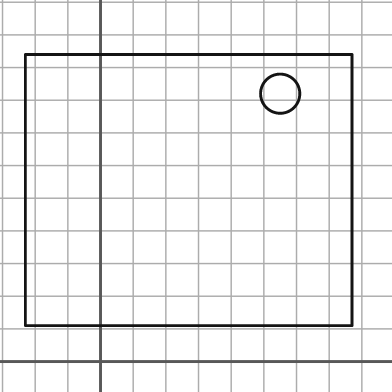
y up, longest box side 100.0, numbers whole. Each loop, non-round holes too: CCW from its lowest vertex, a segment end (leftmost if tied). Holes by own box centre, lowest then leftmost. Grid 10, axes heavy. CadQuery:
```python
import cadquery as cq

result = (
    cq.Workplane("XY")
    .moveTo(-23.0, 11.0)
    .lineTo(77.0, 11.0)
    .lineTo(77.0, 94.0)
    .lineTo(-23.0, 94.0)
    .close()
    .moveTo(55.0, 82.0)
    .circle(6.0)
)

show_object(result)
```